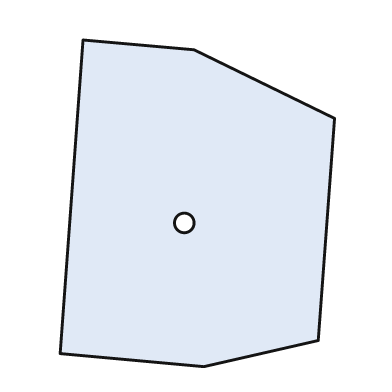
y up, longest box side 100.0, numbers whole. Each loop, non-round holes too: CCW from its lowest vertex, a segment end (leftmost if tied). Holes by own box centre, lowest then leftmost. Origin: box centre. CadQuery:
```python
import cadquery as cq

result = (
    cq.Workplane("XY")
    .moveTo(2.0, -50.0)
    .lineTo(37.0, -42.0)
    .lineTo(42.0, 26.0)
    .lineTo(-1.0, 47.0)
    .lineTo(-35.0, 50.0)
    .lineTo(-42.0, -46.0)
    .close()
    .moveTo(-4.0, -6.0)
    .circle(3.0)
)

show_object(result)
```